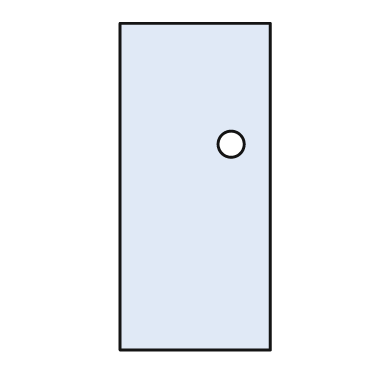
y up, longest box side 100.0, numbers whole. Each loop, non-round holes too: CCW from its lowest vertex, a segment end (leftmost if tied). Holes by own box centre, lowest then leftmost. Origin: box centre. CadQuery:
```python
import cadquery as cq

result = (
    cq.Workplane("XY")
    .moveTo(-23.0, -50.0)
    .lineTo(23.0, -50.0)
    .lineTo(23.0, 50.0)
    .lineTo(-23.0, 50.0)
    .close()
    .moveTo(11.0, 13.0)
    .circle(4.0)
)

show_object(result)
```